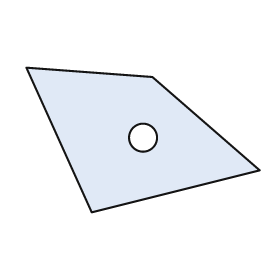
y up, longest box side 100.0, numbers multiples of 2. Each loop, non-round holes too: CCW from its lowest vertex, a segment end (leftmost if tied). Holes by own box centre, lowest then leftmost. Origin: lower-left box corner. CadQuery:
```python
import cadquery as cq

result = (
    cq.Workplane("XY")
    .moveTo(28.0, 0.0)
    .lineTo(100.0, 18.0)
    .lineTo(54.0, 58.0)
    .lineTo(0.0, 62.0)
    .close()
    .moveTo(50.0, 32.0)
    .circle(6.0)
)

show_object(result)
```